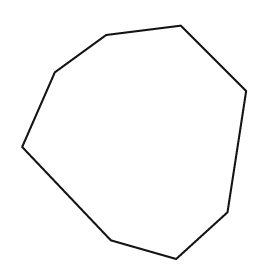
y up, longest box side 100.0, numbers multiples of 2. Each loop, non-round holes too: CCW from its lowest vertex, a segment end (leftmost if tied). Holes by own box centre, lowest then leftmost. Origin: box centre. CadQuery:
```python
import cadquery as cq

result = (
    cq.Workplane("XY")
    .moveTo(18.0, -50.0)
    .lineTo(40.0, -30.0)
    .lineTo(48.0, 22.0)
    .lineTo(20.0, 50.0)
    .lineTo(-12.0, 46.0)
    .lineTo(-34.0, 30.0)
    .lineTo(-48.0, -2.0)
    .lineTo(-10.0, -42.0)
    .close()
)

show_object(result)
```